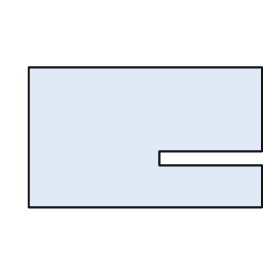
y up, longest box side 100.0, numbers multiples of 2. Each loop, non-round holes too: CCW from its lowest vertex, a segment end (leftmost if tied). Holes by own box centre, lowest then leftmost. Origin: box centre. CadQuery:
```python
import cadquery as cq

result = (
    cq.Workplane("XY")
    .moveTo(-50.0, -30.0)
    .lineTo(50.0, -30.0)
    .lineTo(50.0, -12.0)
    .lineTo(6.0, -12.0)
    .lineTo(6.0, -6.0)
    .lineTo(50.0, -6.0)
    .lineTo(50.0, 30.0)
    .lineTo(-50.0, 30.0)
    .close()
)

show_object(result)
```